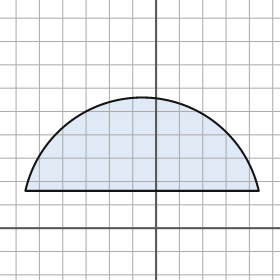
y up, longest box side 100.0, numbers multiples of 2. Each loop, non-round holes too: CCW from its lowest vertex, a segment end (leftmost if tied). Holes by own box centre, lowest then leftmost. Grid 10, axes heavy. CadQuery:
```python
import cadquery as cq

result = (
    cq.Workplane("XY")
    .moveTo(-56.0, 16.0)
    .lineTo(44.0, 16.0)
    .threePointArc((-6.0, 56.0), (-56.0, 16.0))
    .close()
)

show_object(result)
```